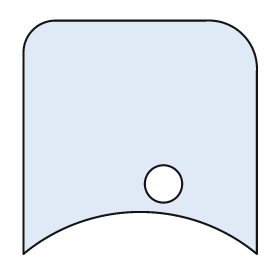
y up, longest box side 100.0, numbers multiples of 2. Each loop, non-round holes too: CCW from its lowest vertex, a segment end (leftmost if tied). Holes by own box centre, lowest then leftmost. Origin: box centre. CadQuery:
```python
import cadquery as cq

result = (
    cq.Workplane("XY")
    .moveTo(-50.0, -50.0)
    .threePointArc((0.0, -32.0), (50.0, -50.0))
    .lineTo(50.0, 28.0)
    .threePointArc((44.0, 44.0), (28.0, 50.0))
    .lineTo(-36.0, 50.0)
    .threePointArc((-46.0, 46.0), (-50.0, 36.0))
    .close()
    .moveTo(10.0, -20.0)
    .circle(8.0)
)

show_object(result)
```